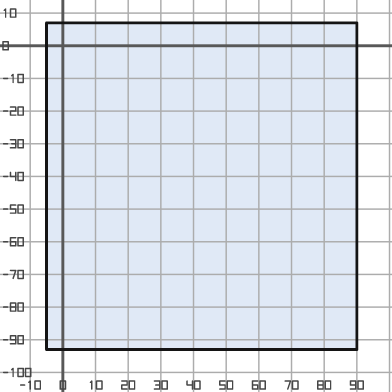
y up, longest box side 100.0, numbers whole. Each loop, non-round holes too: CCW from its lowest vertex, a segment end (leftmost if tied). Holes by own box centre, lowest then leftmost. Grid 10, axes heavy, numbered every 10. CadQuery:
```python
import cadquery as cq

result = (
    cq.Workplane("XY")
    .moveTo(-5.0, -93.0)
    .lineTo(90.0, -93.0)
    .lineTo(90.0, 7.0)
    .lineTo(-5.0, 7.0)
    .close()
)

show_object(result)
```